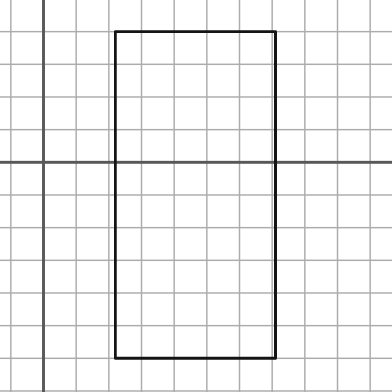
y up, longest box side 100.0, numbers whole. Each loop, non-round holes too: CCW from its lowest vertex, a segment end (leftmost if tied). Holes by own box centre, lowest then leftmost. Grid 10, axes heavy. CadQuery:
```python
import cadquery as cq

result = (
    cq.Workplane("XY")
    .moveTo(22.0, -60.0)
    .lineTo(71.0, -60.0)
    .lineTo(71.0, 40.0)
    .lineTo(22.0, 40.0)
    .close()
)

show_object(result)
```